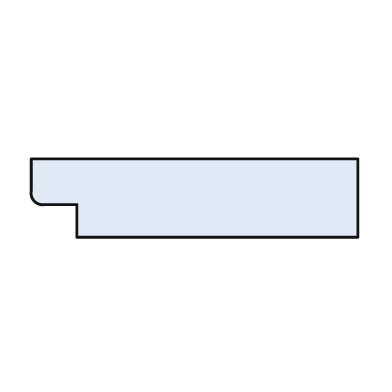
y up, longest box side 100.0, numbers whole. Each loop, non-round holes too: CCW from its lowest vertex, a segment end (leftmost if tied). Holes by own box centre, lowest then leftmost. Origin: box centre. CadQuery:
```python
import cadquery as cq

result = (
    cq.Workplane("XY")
    .moveTo(-36.0, -12.0)
    .lineTo(50.0, -12.0)
    .lineTo(50.0, 12.0)
    .lineTo(-50.0, 12.0)
    .lineTo(-50.0, 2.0)
    .threePointArc((-49.0, -1.0), (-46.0, -2.0))
    .lineTo(-36.0, -2.0)
    .close()
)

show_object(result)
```